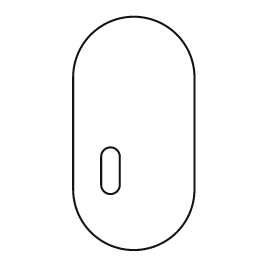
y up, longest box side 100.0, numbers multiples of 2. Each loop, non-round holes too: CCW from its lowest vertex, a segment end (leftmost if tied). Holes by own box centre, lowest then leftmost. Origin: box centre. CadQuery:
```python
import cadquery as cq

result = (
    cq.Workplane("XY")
    .moveTo(-26.0, -24.0)
    .threePointArc((0.0, -50.0), (26.0, -24.0))
    .lineTo(26.0, 24.0)
    .threePointArc((0.0, 50.0), (-26.0, 24.0))
    .close()
    .moveTo(-14.0, -22.0)
    .threePointArc((-10.0, -26.0), (-6.0, -22.0))
    .lineTo(-6.0, -10.0)
    .threePointArc((-10.0, -6.0), (-14.0, -10.0))
    .close()
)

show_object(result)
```